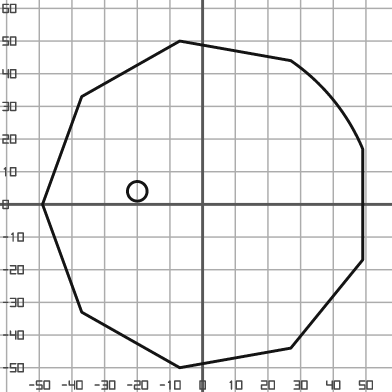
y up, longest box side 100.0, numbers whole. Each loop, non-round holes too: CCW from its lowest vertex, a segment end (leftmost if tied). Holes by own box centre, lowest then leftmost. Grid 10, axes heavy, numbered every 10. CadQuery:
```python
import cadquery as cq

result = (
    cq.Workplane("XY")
    .moveTo(-7.0, -50.0)
    .lineTo(27.0, -44.0)
    .lineTo(49.0, -17.0)
    .lineTo(49.0, 17.0)
    .threePointArc((40.0, 32.0), (27.0, 44.0))
    .lineTo(-7.0, 50.0)
    .lineTo(-37.0, 33.0)
    .lineTo(-49.0, 0.0)
    .lineTo(-37.0, -33.0)
    .close()
    .moveTo(-20.0, 4.0)
    .circle(3.0)
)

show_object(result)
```